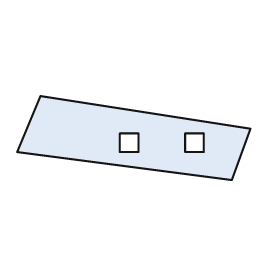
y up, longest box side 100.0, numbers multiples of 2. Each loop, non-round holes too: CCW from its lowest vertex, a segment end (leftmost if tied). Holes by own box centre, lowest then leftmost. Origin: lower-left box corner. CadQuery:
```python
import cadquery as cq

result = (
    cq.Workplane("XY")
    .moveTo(92.0, 0.0)
    .lineTo(100.0, 22.0)
    .lineTo(10.0, 36.0)
    .lineTo(0.0, 12.0)
    .close()
    .moveTo(44.0, 12.0)
    .lineTo(52.0, 12.0)
    .lineTo(52.0, 20.0)
    .lineTo(44.0, 20.0)
    .close()
    .moveTo(72.0, 12.0)
    .lineTo(80.0, 12.0)
    .lineTo(80.0, 20.0)
    .lineTo(72.0, 20.0)
    .close()
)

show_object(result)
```